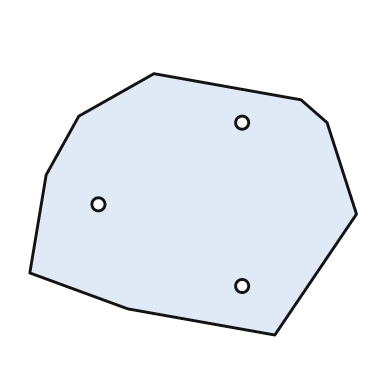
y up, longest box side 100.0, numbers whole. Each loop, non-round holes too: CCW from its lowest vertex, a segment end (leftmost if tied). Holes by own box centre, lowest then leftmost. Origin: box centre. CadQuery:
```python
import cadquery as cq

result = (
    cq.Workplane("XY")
    .moveTo(25.0, -40.0)
    .lineTo(50.0, -3.0)
    .lineTo(41.0, 25.0)
    .lineTo(33.0, 32.0)
    .lineTo(-12.0, 40.0)
    .lineTo(-35.0, 27.0)
    .lineTo(-45.0, 9.0)
    .lineTo(-50.0, -21.0)
    .lineTo(-20.0, -32.0)
    .close()
    .moveTo(15.0, -25.0)
    .circle(2.0)
    .moveTo(-29.0, 0.0)
    .circle(2.0)
    .moveTo(15.0, 25.0)
    .circle(2.0)
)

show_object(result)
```